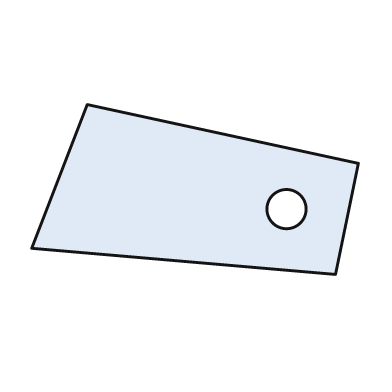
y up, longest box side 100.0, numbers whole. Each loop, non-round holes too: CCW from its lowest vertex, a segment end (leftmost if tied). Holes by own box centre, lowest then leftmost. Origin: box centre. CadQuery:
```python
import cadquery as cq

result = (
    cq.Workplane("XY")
    .moveTo(43.0, -26.0)
    .lineTo(50.0, 8.0)
    .lineTo(-33.0, 26.0)
    .lineTo(-50.0, -18.0)
    .close()
    .moveTo(28.0, -6.0)
    .circle(6.0)
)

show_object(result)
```